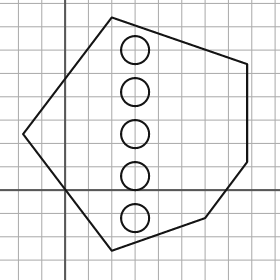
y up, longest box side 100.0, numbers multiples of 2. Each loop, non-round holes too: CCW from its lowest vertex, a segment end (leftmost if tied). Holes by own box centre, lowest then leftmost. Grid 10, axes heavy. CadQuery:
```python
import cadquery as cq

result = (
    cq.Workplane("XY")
    .moveTo(20.0, -26.0)
    .lineTo(60.0, -12.0)
    .lineTo(78.0, 12.0)
    .lineTo(78.0, 54.0)
    .lineTo(20.0, 74.0)
    .lineTo(-18.0, 24.0)
    .close()
    .moveTo(30.0, -12.0)
    .circle(6.0)
    .moveTo(30.0, 6.0)
    .circle(6.0)
    .moveTo(30.0, 24.0)
    .circle(6.0)
    .moveTo(30.0, 42.0)
    .circle(6.0)
    .moveTo(30.0, 60.0)
    .circle(6.0)
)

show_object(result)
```